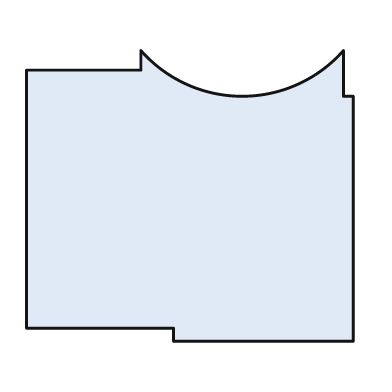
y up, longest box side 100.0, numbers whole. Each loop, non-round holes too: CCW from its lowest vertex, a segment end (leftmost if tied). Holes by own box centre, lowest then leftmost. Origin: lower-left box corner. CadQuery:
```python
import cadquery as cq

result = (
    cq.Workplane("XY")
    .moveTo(45.0, 0.0)
    .lineTo(100.0, 0.0)
    .lineTo(100.0, 75.0)
    .lineTo(97.0, 75.0)
    .lineTo(97.0, 89.0)
    .threePointArc((66.0, 75.0), (35.0, 89.0))
    .lineTo(35.0, 83.0)
    .lineTo(0.0, 83.0)
    .lineTo(0.0, 4.0)
    .lineTo(45.0, 4.0)
    .close()
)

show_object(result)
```